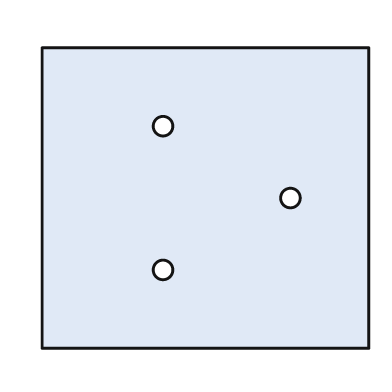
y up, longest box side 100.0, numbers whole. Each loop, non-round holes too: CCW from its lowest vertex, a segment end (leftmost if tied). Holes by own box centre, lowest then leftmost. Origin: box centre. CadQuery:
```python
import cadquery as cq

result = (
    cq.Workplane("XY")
    .moveTo(-50.0, -46.0)
    .lineTo(50.0, -46.0)
    .lineTo(50.0, 46.0)
    .lineTo(-50.0, 46.0)
    .close()
    .moveTo(-13.0, -22.0)
    .circle(3.0)
    .moveTo(26.0, 0.0)
    .circle(3.0)
    .moveTo(-13.0, 22.0)
    .circle(3.0)
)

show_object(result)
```